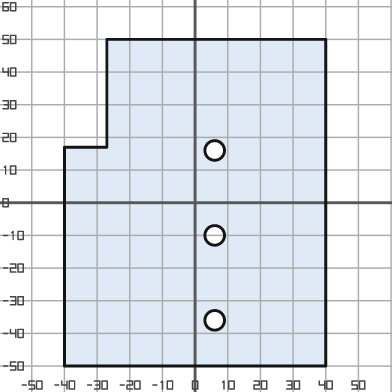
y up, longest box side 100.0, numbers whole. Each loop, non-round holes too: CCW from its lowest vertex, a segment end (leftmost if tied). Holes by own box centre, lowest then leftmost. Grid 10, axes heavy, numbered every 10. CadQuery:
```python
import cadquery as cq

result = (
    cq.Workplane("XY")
    .moveTo(-40.0, -50.0)
    .lineTo(40.0, -50.0)
    .lineTo(40.0, 50.0)
    .lineTo(-27.0, 50.0)
    .lineTo(-27.0, 17.0)
    .lineTo(-40.0, 17.0)
    .close()
    .moveTo(6.0, -36.0)
    .circle(3.0)
    .moveTo(6.0, -10.0)
    .circle(3.0)
    .moveTo(6.0, 16.0)
    .circle(3.0)
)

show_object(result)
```